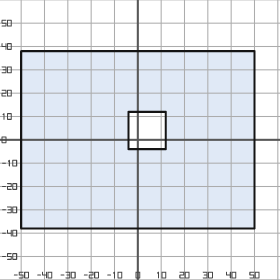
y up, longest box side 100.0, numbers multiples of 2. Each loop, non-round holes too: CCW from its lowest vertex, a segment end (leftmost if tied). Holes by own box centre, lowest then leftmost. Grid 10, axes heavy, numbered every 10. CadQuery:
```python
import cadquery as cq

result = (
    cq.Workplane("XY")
    .moveTo(-50.0, -38.0)
    .lineTo(50.0, -38.0)
    .lineTo(50.0, 38.0)
    .lineTo(-50.0, 38.0)
    .close()
    .moveTo(-4.0, -4.0)
    .lineTo(12.0, -4.0)
    .lineTo(12.0, 12.0)
    .lineTo(-4.0, 12.0)
    .close()
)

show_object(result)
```